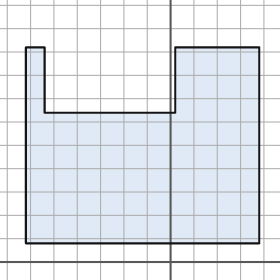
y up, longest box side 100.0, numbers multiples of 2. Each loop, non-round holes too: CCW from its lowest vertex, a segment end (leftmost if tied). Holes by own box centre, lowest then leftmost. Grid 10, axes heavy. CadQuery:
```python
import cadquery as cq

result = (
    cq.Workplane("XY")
    .moveTo(-62.0, 8.0)
    .lineTo(38.0, 8.0)
    .lineTo(38.0, 92.0)
    .lineTo(2.0, 92.0)
    .lineTo(2.0, 64.0)
    .lineTo(-54.0, 64.0)
    .lineTo(-54.0, 92.0)
    .lineTo(-62.0, 92.0)
    .close()
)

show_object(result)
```